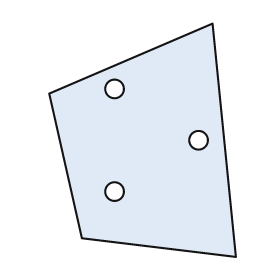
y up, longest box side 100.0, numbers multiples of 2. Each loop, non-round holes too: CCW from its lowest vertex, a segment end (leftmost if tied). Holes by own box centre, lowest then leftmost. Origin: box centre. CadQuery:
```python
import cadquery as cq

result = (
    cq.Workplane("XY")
    .moveTo(40.0, -50.0)
    .lineTo(30.0, 50.0)
    .lineTo(-40.0, 20.0)
    .lineTo(-26.0, -42.0)
    .close()
    .moveTo(-12.0, -22.0)
    .circle(4.0)
    .moveTo(24.0, 0.0)
    .circle(4.0)
    .moveTo(-12.0, 22.0)
    .circle(4.0)
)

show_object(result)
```